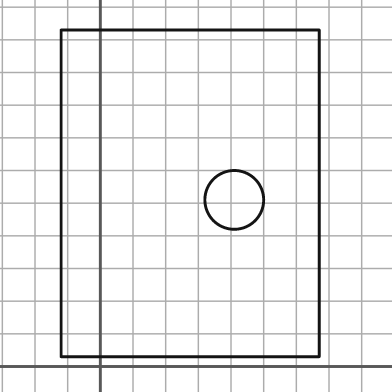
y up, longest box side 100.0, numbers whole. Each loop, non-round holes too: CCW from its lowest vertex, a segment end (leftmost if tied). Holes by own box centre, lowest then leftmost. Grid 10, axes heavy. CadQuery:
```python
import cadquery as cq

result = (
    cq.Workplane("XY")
    .moveTo(-12.0, 3.0)
    .lineTo(67.0, 3.0)
    .lineTo(67.0, 103.0)
    .lineTo(-12.0, 103.0)
    .close()
    .moveTo(41.0, 51.0)
    .circle(9.0)
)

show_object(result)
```